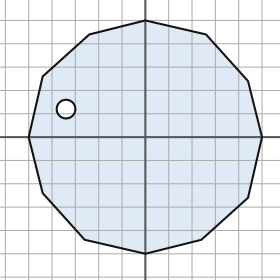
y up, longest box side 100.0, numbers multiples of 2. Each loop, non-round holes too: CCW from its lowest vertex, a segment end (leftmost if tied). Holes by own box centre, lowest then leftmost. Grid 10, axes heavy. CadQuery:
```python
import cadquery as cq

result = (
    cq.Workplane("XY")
    .moveTo(0.0, -50.0)
    .lineTo(24.0, -44.0)
    .lineTo(44.0, -26.0)
    .lineTo(50.0, 0.0)
    .lineTo(44.0, 24.0)
    .lineTo(26.0, 44.0)
    .lineTo(0.0, 50.0)
    .lineTo(-24.0, 44.0)
    .lineTo(-44.0, 26.0)
    .lineTo(-50.0, 0.0)
    .lineTo(-44.0, -24.0)
    .lineTo(-26.0, -44.0)
    .close()
    .moveTo(-34.0, 12.0)
    .circle(4.0)
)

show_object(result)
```